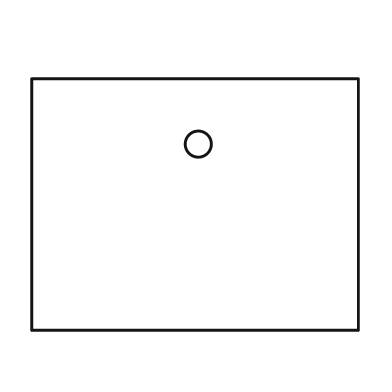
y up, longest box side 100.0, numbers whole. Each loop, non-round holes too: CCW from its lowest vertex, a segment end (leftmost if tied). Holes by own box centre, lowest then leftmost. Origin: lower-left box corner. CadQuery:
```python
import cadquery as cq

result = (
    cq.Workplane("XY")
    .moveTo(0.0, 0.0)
    .lineTo(100.0, 0.0)
    .lineTo(100.0, 77.0)
    .lineTo(0.0, 77.0)
    .close()
    .moveTo(51.0, 57.0)
    .circle(4.0)
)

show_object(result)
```